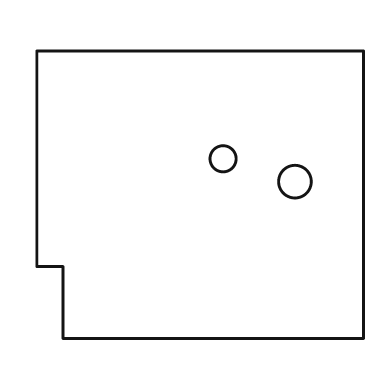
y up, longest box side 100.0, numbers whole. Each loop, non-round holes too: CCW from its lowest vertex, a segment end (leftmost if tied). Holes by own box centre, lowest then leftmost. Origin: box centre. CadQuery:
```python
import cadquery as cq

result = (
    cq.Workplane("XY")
    .moveTo(-42.0, -44.0)
    .lineTo(50.0, -44.0)
    .lineTo(50.0, 44.0)
    .lineTo(-50.0, 44.0)
    .lineTo(-50.0, -22.0)
    .lineTo(-42.0, -22.0)
    .close()
    .moveTo(29.0, 4.0)
    .circle(5.0)
    .moveTo(7.0, 11.0)
    .circle(4.0)
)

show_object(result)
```